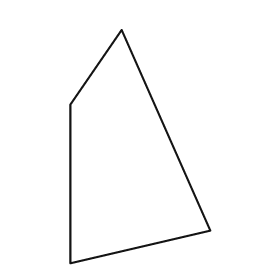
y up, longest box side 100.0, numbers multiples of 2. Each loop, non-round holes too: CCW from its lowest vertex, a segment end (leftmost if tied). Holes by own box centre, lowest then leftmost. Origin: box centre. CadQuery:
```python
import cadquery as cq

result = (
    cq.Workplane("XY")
    .moveTo(-30.0, -50.0)
    .lineTo(30.0, -36.0)
    .lineTo(-8.0, 50.0)
    .lineTo(-30.0, 18.0)
    .close()
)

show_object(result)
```